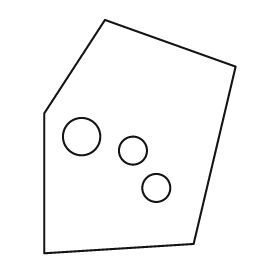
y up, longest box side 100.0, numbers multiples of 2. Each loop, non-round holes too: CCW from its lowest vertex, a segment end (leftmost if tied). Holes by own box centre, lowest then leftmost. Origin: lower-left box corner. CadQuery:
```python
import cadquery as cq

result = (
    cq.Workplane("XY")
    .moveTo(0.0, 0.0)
    .lineTo(64.0, 4.0)
    .lineTo(82.0, 80.0)
    .lineTo(26.0, 100.0)
    .lineTo(0.0, 60.0)
    .close()
    .moveTo(48.0, 28.0)
    .circle(6.0)
    .moveTo(38.0, 44.0)
    .circle(6.0)
    .moveTo(16.0, 50.0)
    .circle(8.0)
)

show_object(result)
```